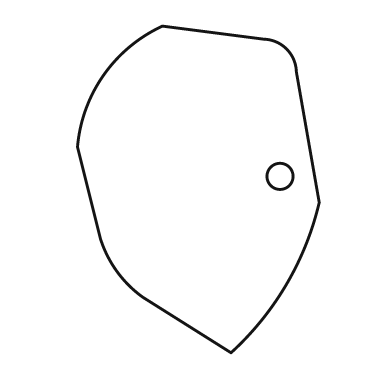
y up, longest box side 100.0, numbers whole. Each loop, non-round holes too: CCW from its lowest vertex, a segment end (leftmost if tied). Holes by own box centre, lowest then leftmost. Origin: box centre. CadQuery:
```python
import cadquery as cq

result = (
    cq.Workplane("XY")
    .moveTo(10.0, -50.0)
    .threePointArc((27.0, -29.0), (37.0, -4.0))
    .lineTo(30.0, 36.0)
    .threePointArc((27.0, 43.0), (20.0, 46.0))
    .lineTo(-11.0, 50.0)
    .threePointArc((-29.0, 35.0), (-37.0, 13.0))
    .lineTo(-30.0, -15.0)
    .threePointArc((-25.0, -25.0), (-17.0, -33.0))
    .close()
    .moveTo(25.0, 4.0)
    .circle(4.0)
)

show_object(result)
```